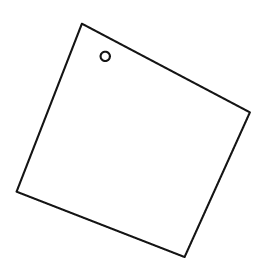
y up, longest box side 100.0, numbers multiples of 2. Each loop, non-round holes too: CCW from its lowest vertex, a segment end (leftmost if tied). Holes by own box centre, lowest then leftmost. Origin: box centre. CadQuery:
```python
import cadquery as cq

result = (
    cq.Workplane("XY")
    .moveTo(22.0, -50.0)
    .lineTo(50.0, 12.0)
    .lineTo(-22.0, 50.0)
    .lineTo(-50.0, -22.0)
    .close()
    .moveTo(-12.0, 36.0)
    .circle(2.0)
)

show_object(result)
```